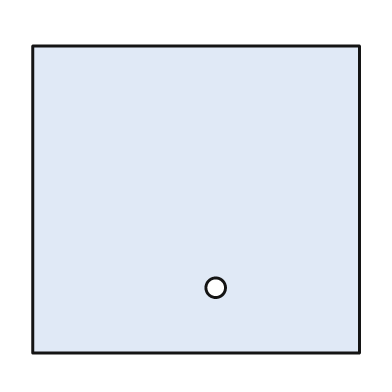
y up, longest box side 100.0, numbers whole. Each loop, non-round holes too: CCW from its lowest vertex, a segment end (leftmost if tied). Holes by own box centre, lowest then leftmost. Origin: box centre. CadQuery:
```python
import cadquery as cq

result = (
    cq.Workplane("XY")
    .moveTo(-50.0, -47.0)
    .lineTo(50.0, -47.0)
    .lineTo(50.0, 47.0)
    .lineTo(-50.0, 47.0)
    .close()
    .moveTo(6.0, -27.0)
    .circle(3.0)
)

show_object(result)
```